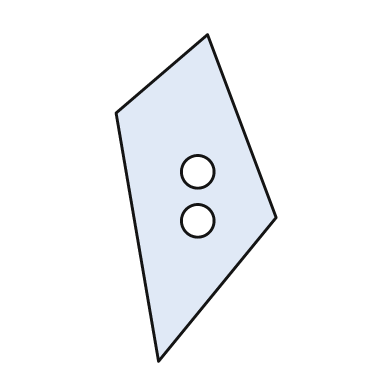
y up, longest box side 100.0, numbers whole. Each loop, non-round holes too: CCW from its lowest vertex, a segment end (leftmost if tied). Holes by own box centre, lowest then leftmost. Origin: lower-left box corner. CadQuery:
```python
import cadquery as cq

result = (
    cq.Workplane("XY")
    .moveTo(13.0, 0.0)
    .lineTo(49.0, 44.0)
    .lineTo(28.0, 100.0)
    .lineTo(0.0, 76.0)
    .close()
    .moveTo(25.0, 43.0)
    .circle(5.0)
    .moveTo(25.0, 58.0)
    .circle(5.0)
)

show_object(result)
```